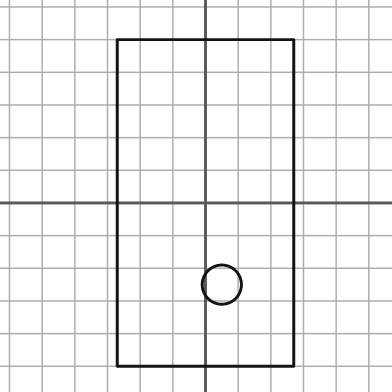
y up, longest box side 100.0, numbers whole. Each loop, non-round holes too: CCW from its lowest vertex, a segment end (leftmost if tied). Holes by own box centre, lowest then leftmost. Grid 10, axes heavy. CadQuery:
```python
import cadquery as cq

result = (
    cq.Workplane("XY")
    .moveTo(-27.0, -50.0)
    .lineTo(27.0, -50.0)
    .lineTo(27.0, 50.0)
    .lineTo(-27.0, 50.0)
    .close()
    .moveTo(5.0, -25.0)
    .circle(6.0)
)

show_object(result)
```